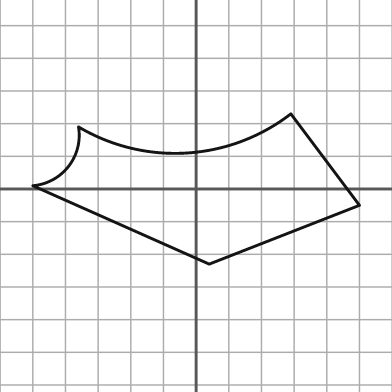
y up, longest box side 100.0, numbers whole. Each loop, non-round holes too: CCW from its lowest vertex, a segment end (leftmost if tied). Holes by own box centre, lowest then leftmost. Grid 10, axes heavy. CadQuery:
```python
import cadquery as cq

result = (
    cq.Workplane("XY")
    .moveTo(4.0, -23.0)
    .lineTo(50.0, -5.0)
    .lineTo(29.0, 23.0)
    .threePointArc((-3.0, 11.0), (-36.0, 19.0))
    .threePointArc((-39.0, 7.0), (-50.0, 1.0))
    .close()
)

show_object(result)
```